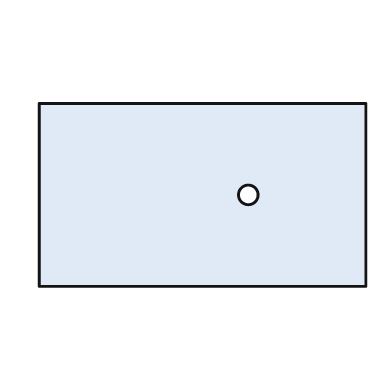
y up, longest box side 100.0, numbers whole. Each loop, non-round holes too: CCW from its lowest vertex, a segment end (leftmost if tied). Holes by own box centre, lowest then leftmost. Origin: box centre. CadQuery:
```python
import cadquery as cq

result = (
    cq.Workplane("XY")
    .moveTo(-50.0, -28.0)
    .lineTo(50.0, -28.0)
    .lineTo(50.0, 28.0)
    .lineTo(-50.0, 28.0)
    .close()
    .moveTo(14.0, 0.0)
    .circle(3.0)
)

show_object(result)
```